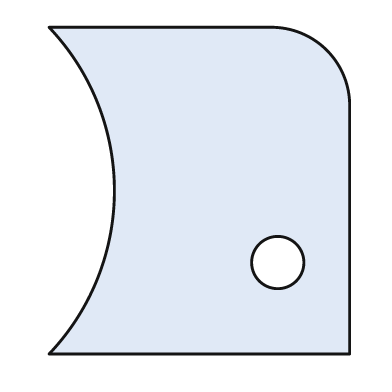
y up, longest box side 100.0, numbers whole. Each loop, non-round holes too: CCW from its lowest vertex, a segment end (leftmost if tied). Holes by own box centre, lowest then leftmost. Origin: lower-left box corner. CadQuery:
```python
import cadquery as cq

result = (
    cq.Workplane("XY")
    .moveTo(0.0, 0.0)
    .lineTo(92.0, 0.0)
    .lineTo(92.0, 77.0)
    .threePointArc((85.0, 93.0), (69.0, 100.0))
    .lineTo(0.0, 100.0)
    .threePointArc((20.0, 50.0), (0.0, 0.0))
    .close()
    .moveTo(70.0, 28.0)
    .circle(8.0)
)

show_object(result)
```